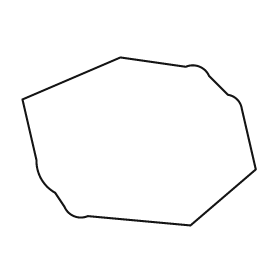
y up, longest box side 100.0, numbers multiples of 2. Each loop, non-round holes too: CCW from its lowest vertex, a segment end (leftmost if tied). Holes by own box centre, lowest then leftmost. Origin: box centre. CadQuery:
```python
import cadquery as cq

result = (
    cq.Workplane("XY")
    .moveTo(22.0, -36.0)
    .lineTo(50.0, -12.0)
    .lineTo(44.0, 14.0)
    .threePointArc((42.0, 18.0), (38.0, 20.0))
    .lineTo(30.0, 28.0)
    .threePointArc((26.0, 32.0), (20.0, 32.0))
    .lineTo(-8.0, 36.0)
    .lineTo(-50.0, 18.0)
    .lineTo(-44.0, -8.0)
    .threePointArc((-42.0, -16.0), (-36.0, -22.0))
    .lineTo(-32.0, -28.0)
    .threePointArc((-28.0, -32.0), (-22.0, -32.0))
    .close()
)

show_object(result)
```